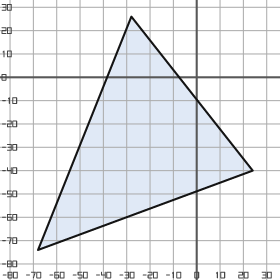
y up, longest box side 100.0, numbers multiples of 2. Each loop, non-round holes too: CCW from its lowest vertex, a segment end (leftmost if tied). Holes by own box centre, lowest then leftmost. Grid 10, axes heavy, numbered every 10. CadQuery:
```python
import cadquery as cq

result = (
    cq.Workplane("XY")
    .moveTo(-68.0, -74.0)
    .lineTo(24.0, -40.0)
    .lineTo(-28.0, 26.0)
    .close()
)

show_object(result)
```